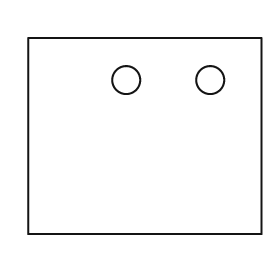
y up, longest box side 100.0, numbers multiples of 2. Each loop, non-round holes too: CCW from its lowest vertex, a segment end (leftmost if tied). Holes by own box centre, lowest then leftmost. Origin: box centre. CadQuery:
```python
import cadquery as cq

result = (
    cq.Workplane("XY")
    .moveTo(-50.0, -42.0)
    .lineTo(50.0, -42.0)
    .lineTo(50.0, 42.0)
    .lineTo(-50.0, 42.0)
    .close()
    .moveTo(-8.0, 24.0)
    .circle(6.0)
    .moveTo(28.0, 24.0)
    .circle(6.0)
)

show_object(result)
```